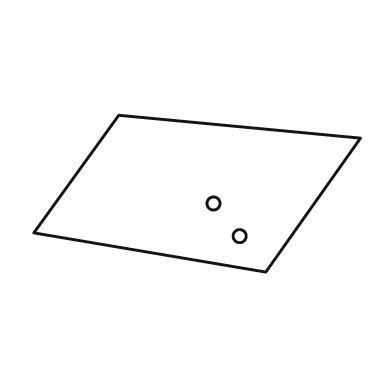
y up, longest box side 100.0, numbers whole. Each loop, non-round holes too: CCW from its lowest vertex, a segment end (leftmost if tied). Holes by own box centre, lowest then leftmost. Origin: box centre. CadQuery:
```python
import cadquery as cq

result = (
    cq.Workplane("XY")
    .moveTo(21.0, -24.0)
    .lineTo(50.0, 17.0)
    .lineTo(-24.0, 24.0)
    .lineTo(-50.0, -12.0)
    .close()
    .moveTo(13.0, -13.0)
    .circle(2.0)
    .moveTo(5.0, -3.0)
    .circle(2.0)
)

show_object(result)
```